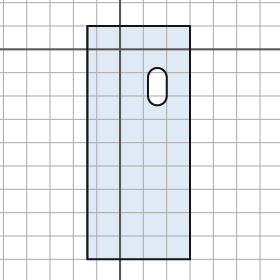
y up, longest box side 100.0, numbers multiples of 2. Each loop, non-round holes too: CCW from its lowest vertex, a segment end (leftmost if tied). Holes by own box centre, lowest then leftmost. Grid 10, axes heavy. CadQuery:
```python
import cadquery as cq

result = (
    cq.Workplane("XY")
    .moveTo(-14.0, -90.0)
    .lineTo(30.0, -90.0)
    .lineTo(30.0, 10.0)
    .lineTo(-14.0, 10.0)
    .close()
    .moveTo(12.0, -20.0)
    .threePointArc((16.0, -24.0), (20.0, -20.0))
    .lineTo(20.0, -12.0)
    .threePointArc((16.0, -8.0), (12.0, -12.0))
    .close()
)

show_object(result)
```